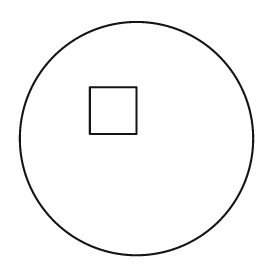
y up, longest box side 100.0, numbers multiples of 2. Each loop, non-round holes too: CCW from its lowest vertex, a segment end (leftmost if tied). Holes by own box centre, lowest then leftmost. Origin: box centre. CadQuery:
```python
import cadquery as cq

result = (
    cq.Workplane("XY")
    .moveTo(0.0, 0.0)
    .circle(50.0)
    .moveTo(-20.0, 2.0)
    .lineTo(0.0, 2.0)
    .lineTo(0.0, 22.0)
    .lineTo(-20.0, 22.0)
    .close()
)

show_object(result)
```